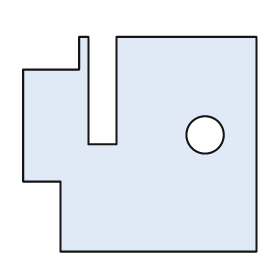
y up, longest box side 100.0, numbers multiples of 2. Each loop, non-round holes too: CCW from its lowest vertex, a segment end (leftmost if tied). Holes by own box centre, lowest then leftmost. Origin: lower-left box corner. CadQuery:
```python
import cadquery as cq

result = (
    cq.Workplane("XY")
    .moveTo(16.0, 0.0)
    .lineTo(100.0, 0.0)
    .lineTo(100.0, 92.0)
    .lineTo(40.0, 92.0)
    .lineTo(40.0, 46.0)
    .lineTo(28.0, 46.0)
    .lineTo(28.0, 92.0)
    .lineTo(24.0, 92.0)
    .lineTo(24.0, 78.0)
    .lineTo(0.0, 78.0)
    .lineTo(0.0, 30.0)
    .lineTo(16.0, 30.0)
    .close()
    .moveTo(78.0, 50.0)
    .circle(8.0)
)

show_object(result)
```